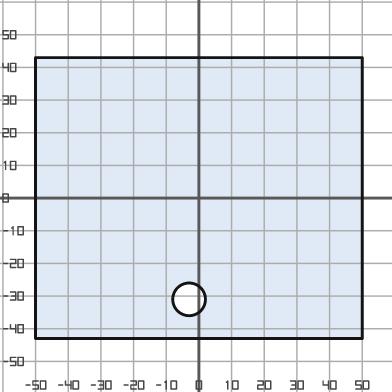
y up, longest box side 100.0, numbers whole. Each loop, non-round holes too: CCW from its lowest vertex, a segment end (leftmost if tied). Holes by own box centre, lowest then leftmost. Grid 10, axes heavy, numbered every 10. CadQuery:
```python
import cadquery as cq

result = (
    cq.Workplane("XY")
    .moveTo(-50.0, -43.0)
    .lineTo(50.0, -43.0)
    .lineTo(50.0, 43.0)
    .lineTo(-50.0, 43.0)
    .close()
    .moveTo(-3.0, -31.0)
    .circle(5.0)
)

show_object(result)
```